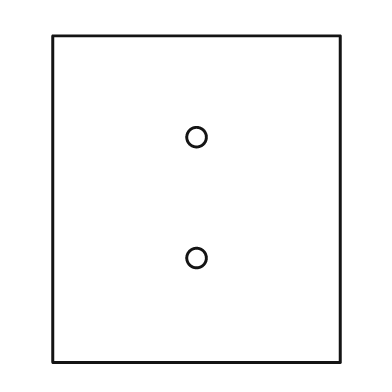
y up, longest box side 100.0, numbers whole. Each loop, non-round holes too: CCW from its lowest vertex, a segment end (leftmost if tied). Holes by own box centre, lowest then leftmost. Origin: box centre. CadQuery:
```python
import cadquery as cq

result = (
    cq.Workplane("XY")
    .moveTo(-44.0, -50.0)
    .lineTo(44.0, -50.0)
    .lineTo(44.0, 50.0)
    .lineTo(-44.0, 50.0)
    .close()
    .moveTo(0.0, -18.0)
    .circle(3.0)
    .moveTo(0.0, 19.0)
    .circle(3.0)
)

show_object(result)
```